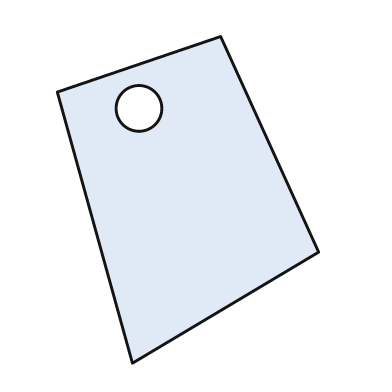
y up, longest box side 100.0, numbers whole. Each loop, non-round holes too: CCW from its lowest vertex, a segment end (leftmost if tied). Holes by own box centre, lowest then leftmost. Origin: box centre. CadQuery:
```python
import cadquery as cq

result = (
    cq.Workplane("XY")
    .moveTo(-17.0, -50.0)
    .lineTo(40.0, -16.0)
    .lineTo(10.0, 50.0)
    .lineTo(-40.0, 33.0)
    .close()
    .moveTo(-15.0, 28.0)
    .circle(7.0)
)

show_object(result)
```